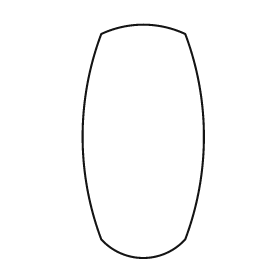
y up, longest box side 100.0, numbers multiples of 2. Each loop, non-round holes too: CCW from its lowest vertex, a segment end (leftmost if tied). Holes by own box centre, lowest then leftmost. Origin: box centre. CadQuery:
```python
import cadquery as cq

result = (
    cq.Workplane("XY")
    .moveTo(-18.0, -42.0)
    .threePointArc((0.0, -50.0), (18.0, -42.0))
    .threePointArc((26.0, 2.0), (18.0, 46.0))
    .threePointArc((0.0, 50.0), (-18.0, 46.0))
    .threePointArc((-26.0, 2.0), (-18.0, -42.0))
    .close()
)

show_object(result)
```